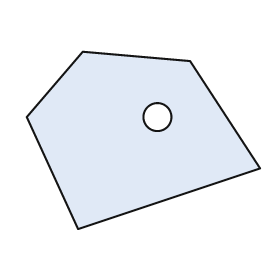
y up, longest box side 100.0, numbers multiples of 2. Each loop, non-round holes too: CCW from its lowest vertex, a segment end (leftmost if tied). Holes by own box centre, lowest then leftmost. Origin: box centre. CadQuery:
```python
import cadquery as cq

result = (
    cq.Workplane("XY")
    .moveTo(-28.0, -38.0)
    .lineTo(50.0, -12.0)
    .lineTo(20.0, 34.0)
    .lineTo(-26.0, 38.0)
    .lineTo(-50.0, 10.0)
    .close()
    .moveTo(6.0, 10.0)
    .circle(6.0)
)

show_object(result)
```